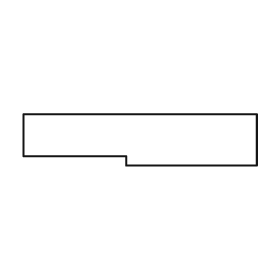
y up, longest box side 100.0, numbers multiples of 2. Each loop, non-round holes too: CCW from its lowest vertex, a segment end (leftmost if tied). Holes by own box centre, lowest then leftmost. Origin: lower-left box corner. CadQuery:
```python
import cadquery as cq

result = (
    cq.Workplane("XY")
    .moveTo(44.0, 0.0)
    .lineTo(100.0, 0.0)
    .lineTo(100.0, 22.0)
    .lineTo(0.0, 22.0)
    .lineTo(0.0, 4.0)
    .lineTo(44.0, 4.0)
    .close()
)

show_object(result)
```